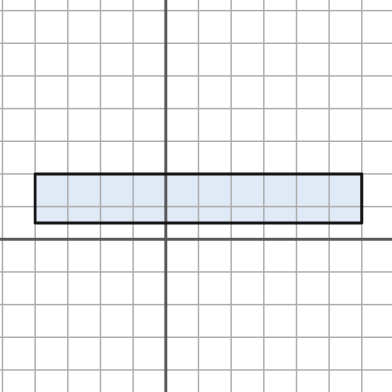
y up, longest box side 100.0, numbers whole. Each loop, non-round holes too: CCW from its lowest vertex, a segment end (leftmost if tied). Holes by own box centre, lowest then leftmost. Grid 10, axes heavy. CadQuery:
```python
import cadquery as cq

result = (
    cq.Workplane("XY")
    .moveTo(-40.0, 5.0)
    .lineTo(60.0, 5.0)
    .lineTo(60.0, 20.0)
    .lineTo(-40.0, 20.0)
    .close()
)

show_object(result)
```